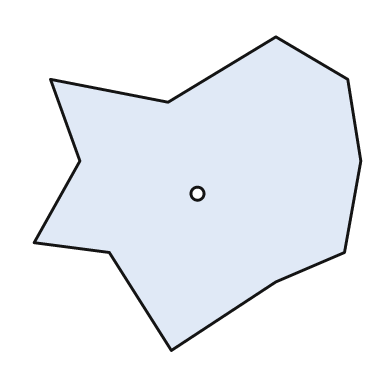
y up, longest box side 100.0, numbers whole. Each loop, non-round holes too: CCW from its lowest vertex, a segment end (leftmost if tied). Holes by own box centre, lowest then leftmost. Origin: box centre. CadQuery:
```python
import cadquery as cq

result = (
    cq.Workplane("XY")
    .moveTo(-8.0, -48.0)
    .lineTo(24.0, -27.0)
    .lineTo(45.0, -18.0)
    .lineTo(50.0, 10.0)
    .lineTo(46.0, 35.0)
    .lineTo(24.0, 48.0)
    .lineTo(-9.0, 28.0)
    .lineTo(-45.0, 35.0)
    .lineTo(-36.0, 10.0)
    .lineTo(-50.0, -15.0)
    .lineTo(-27.0, -18.0)
    .close()
    .moveTo(0.0, 0.0)
    .circle(2.0)
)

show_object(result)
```